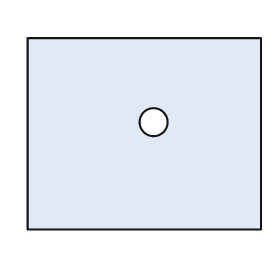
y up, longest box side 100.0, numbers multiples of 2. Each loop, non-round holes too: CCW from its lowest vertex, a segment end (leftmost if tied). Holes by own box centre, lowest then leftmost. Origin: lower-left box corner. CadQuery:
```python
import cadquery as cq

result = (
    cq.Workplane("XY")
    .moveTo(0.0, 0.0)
    .lineTo(100.0, 0.0)
    .lineTo(100.0, 82.0)
    .lineTo(0.0, 82.0)
    .close()
    .moveTo(54.0, 46.0)
    .circle(6.0)
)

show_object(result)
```